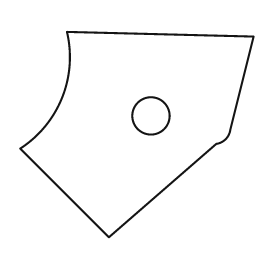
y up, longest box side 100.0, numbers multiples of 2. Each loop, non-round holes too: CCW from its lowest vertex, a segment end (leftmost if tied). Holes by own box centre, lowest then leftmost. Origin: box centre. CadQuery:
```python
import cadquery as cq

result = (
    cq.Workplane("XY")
    .moveTo(-12.0, -44.0)
    .lineTo(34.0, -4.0)
    .threePointArc((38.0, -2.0), (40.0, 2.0))
    .lineTo(50.0, 42.0)
    .lineTo(-30.0, 44.0)
    .threePointArc((-32.0, 16.0), (-50.0, -6.0))
    .close()
    .moveTo(6.0, 8.0)
    .circle(8.0)
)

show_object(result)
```